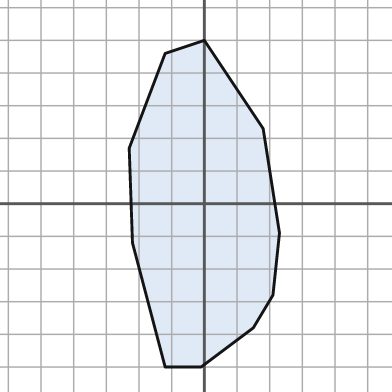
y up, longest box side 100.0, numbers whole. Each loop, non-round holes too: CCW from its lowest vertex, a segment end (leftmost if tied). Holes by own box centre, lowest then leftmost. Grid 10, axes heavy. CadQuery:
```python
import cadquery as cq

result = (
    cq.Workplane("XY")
    .moveTo(-12.0, -50.0)
    .lineTo(-1.0, -50.0)
    .lineTo(15.0, -38.0)
    .lineTo(21.0, -28.0)
    .lineTo(23.0, -9.0)
    .lineTo(18.0, 23.0)
    .lineTo(0.0, 50.0)
    .lineTo(-12.0, 46.0)
    .lineTo(-23.0, 17.0)
    .lineTo(-22.0, -12.0)
    .close()
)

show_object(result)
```